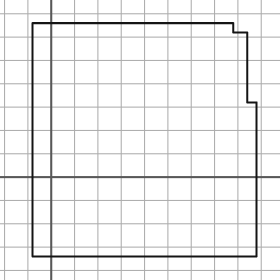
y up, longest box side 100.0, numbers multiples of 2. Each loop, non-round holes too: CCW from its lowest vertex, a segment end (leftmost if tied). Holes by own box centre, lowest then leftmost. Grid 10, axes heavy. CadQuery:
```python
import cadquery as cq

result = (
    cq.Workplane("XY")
    .moveTo(-8.0, -34.0)
    .lineTo(88.0, -34.0)
    .lineTo(88.0, 32.0)
    .lineTo(84.0, 32.0)
    .lineTo(84.0, 62.0)
    .lineTo(78.0, 62.0)
    .lineTo(78.0, 66.0)
    .lineTo(-8.0, 66.0)
    .close()
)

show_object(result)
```